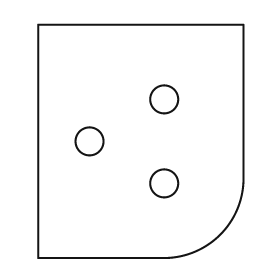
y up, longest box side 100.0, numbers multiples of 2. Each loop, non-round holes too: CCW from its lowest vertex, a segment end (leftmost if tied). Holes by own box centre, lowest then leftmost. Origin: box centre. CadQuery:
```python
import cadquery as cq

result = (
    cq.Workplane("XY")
    .moveTo(-44.0, -50.0)
    .lineTo(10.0, -50.0)
    .threePointArc((34.0, -40.0), (44.0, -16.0))
    .lineTo(44.0, 50.0)
    .lineTo(-44.0, 50.0)
    .close()
    .moveTo(10.0, -18.0)
    .circle(6.0)
    .moveTo(-22.0, 0.0)
    .circle(6.0)
    .moveTo(10.0, 18.0)
    .circle(6.0)
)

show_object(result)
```